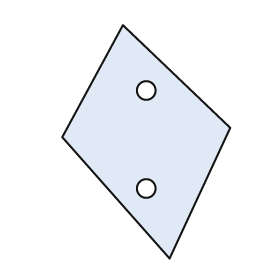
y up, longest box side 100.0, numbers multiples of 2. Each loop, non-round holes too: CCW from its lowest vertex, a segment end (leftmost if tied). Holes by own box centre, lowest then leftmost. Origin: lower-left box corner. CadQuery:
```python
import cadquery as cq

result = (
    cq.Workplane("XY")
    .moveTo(46.0, 0.0)
    .lineTo(72.0, 56.0)
    .lineTo(26.0, 100.0)
    .lineTo(0.0, 52.0)
    .close()
    .moveTo(36.0, 30.0)
    .circle(4.0)
    .moveTo(36.0, 72.0)
    .circle(4.0)
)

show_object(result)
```